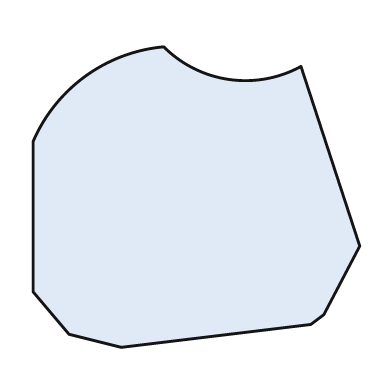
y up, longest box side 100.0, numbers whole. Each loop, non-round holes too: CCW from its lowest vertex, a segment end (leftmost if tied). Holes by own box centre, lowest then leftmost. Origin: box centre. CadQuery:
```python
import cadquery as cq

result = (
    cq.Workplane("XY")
    .moveTo(-23.0, -46.0)
    .lineTo(35.0, -39.0)
    .lineTo(39.0, -36.0)
    .lineTo(50.0, -15.0)
    .lineTo(32.0, 40.0)
    .threePointArc((10.0, 36.0), (-10.0, 46.0))
    .threePointArc((-34.0, 37.0), (-50.0, 17.0))
    .lineTo(-50.0, -29.0)
    .lineTo(-39.0, -42.0)
    .close()
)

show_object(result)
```